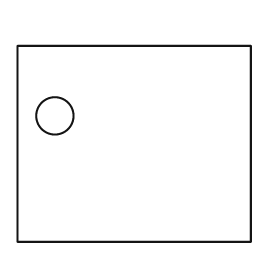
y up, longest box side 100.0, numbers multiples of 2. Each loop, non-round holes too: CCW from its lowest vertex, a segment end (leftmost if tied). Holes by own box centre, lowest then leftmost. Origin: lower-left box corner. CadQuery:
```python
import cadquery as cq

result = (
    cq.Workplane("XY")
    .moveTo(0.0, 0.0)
    .lineTo(100.0, 0.0)
    .lineTo(100.0, 84.0)
    .lineTo(0.0, 84.0)
    .close()
    .moveTo(16.0, 54.0)
    .circle(8.0)
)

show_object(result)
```